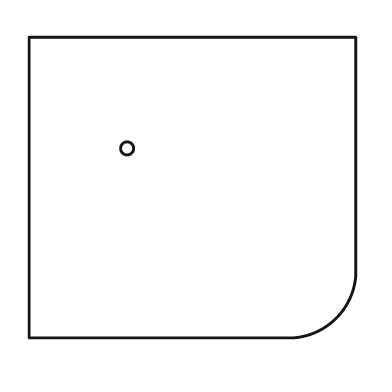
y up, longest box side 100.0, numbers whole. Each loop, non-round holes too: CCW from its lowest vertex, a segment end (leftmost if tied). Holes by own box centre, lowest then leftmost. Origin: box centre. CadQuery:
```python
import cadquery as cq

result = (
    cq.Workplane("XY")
    .moveTo(-50.0, -46.0)
    .lineTo(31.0, -46.0)
    .threePointArc((44.0, -40.0), (50.0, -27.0))
    .lineTo(50.0, 46.0)
    .lineTo(-50.0, 46.0)
    .close()
    .moveTo(-20.0, 12.0)
    .circle(2.0)
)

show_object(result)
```